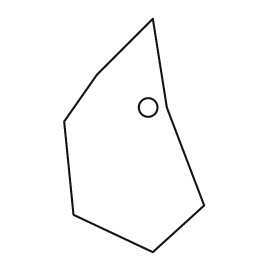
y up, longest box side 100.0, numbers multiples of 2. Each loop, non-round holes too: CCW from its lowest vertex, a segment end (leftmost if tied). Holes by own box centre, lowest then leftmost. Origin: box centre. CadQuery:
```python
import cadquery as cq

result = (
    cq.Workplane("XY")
    .moveTo(8.0, -50.0)
    .lineTo(30.0, -30.0)
    .lineTo(14.0, 12.0)
    .lineTo(8.0, 50.0)
    .lineTo(-16.0, 26.0)
    .lineTo(-30.0, 6.0)
    .lineTo(-26.0, -34.0)
    .close()
    .moveTo(6.0, 12.0)
    .circle(4.0)
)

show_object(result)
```